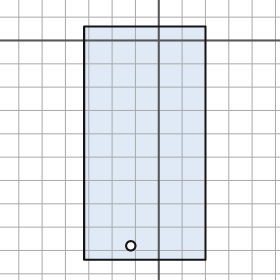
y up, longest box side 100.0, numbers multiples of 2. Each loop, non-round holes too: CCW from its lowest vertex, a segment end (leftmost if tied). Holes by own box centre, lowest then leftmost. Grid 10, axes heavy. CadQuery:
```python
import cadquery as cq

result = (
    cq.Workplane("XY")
    .moveTo(-32.0, -94.0)
    .lineTo(20.0, -94.0)
    .lineTo(20.0, 6.0)
    .lineTo(-32.0, 6.0)
    .close()
    .moveTo(-12.0, -88.0)
    .circle(2.0)
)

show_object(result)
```